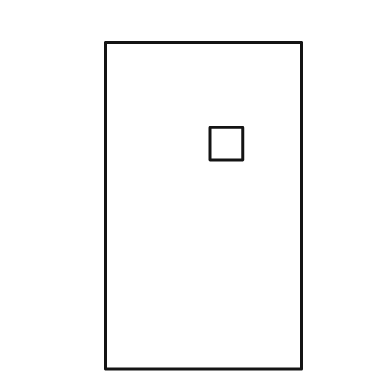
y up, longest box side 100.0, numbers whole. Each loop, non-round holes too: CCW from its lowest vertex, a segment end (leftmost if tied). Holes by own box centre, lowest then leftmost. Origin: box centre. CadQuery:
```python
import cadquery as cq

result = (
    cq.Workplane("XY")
    .moveTo(-30.0, -50.0)
    .lineTo(30.0, -50.0)
    .lineTo(30.0, 50.0)
    .lineTo(-30.0, 50.0)
    .close()
    .moveTo(2.0, 14.0)
    .lineTo(12.0, 14.0)
    .lineTo(12.0, 24.0)
    .lineTo(2.0, 24.0)
    .close()
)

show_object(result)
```